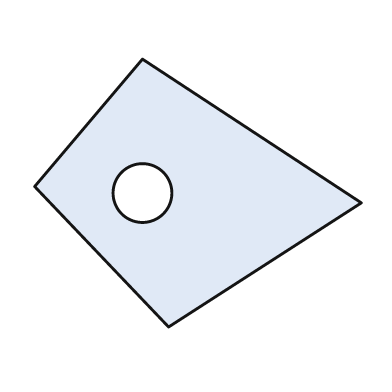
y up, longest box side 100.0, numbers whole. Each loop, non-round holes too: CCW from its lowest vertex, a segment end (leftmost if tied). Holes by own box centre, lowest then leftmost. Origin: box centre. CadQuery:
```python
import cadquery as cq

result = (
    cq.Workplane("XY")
    .moveTo(-9.0, -41.0)
    .lineTo(50.0, -3.0)
    .lineTo(-17.0, 41.0)
    .lineTo(-50.0, 2.0)
    .close()
    .moveTo(-17.0, 0.0)
    .circle(9.0)
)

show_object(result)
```